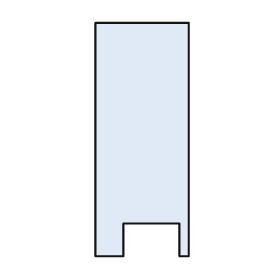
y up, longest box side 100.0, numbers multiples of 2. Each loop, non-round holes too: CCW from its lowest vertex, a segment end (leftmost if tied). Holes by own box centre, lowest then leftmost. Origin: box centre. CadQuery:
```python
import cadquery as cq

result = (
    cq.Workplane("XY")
    .moveTo(-20.0, -50.0)
    .lineTo(-8.0, -50.0)
    .lineTo(-8.0, -36.0)
    .lineTo(16.0, -36.0)
    .lineTo(16.0, -50.0)
    .lineTo(20.0, -50.0)
    .lineTo(20.0, 50.0)
    .lineTo(-20.0, 50.0)
    .close()
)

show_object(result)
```